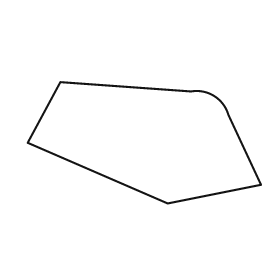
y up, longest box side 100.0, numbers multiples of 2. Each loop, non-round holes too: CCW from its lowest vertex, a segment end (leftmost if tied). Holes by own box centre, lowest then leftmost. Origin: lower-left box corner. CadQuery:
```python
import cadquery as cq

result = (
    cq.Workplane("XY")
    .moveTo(60.0, 0.0)
    .lineTo(100.0, 8.0)
    .lineTo(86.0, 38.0)
    .threePointArc((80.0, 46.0), (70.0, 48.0))
    .lineTo(14.0, 52.0)
    .lineTo(0.0, 26.0)
    .close()
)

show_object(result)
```